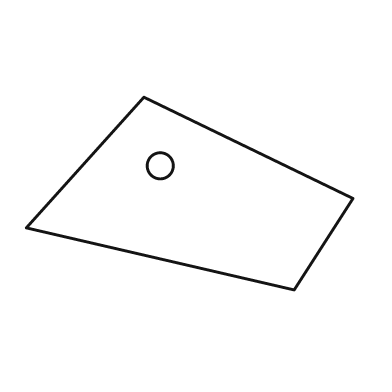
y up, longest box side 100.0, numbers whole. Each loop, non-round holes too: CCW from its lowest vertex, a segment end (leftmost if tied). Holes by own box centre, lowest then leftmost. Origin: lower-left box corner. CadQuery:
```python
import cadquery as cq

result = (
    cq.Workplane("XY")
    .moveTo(82.0, 0.0)
    .lineTo(100.0, 28.0)
    .lineTo(36.0, 59.0)
    .lineTo(0.0, 19.0)
    .close()
    .moveTo(41.0, 38.0)
    .circle(4.0)
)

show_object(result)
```